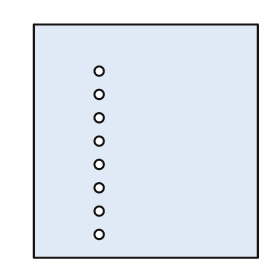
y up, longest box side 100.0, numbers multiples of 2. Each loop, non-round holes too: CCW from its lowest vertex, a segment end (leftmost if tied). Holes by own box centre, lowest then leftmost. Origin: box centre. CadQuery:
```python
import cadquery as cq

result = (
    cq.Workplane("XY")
    .moveTo(-48.0, -50.0)
    .lineTo(48.0, -50.0)
    .lineTo(48.0, 50.0)
    .lineTo(-48.0, 50.0)
    .close()
    .moveTo(-20.0, -40.0)
    .circle(2.0)
    .moveTo(-20.0, -30.0)
    .circle(2.0)
    .moveTo(-20.0, -20.0)
    .circle(2.0)
    .moveTo(-20.0, -10.0)
    .circle(2.0)
    .moveTo(-20.0, 0.0)
    .circle(2.0)
    .moveTo(-20.0, 10.0)
    .circle(2.0)
    .moveTo(-20.0, 20.0)
    .circle(2.0)
    .moveTo(-20.0, 30.0)
    .circle(2.0)
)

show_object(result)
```